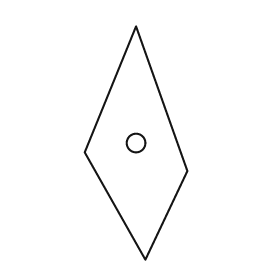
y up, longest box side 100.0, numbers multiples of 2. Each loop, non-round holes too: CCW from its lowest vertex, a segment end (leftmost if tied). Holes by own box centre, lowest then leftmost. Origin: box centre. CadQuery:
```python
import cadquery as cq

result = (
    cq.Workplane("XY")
    .moveTo(4.0, -50.0)
    .lineTo(22.0, -12.0)
    .lineTo(0.0, 50.0)
    .lineTo(-22.0, -4.0)
    .close()
    .moveTo(0.0, 0.0)
    .circle(4.0)
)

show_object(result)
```